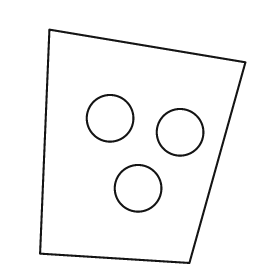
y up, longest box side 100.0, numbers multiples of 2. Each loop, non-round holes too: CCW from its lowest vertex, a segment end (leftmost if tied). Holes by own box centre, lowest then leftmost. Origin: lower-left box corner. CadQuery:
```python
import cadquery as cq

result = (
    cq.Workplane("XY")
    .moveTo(64.0, 0.0)
    .lineTo(88.0, 86.0)
    .lineTo(4.0, 100.0)
    .lineTo(0.0, 4.0)
    .close()
    .moveTo(42.0, 32.0)
    .circle(10.0)
    .moveTo(60.0, 56.0)
    .circle(10.0)
    .moveTo(30.0, 62.0)
    .circle(10.0)
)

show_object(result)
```